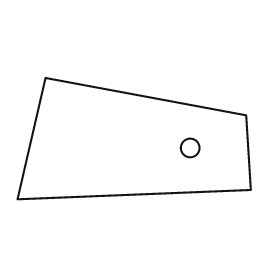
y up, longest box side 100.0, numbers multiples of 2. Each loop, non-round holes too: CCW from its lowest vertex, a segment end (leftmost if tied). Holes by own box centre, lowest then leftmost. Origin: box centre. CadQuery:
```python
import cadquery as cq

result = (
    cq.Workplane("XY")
    .moveTo(-50.0, -26.0)
    .lineTo(50.0, -22.0)
    .lineTo(48.0, 10.0)
    .lineTo(-38.0, 26.0)
    .close()
    .moveTo(24.0, -4.0)
    .circle(4.0)
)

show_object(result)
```